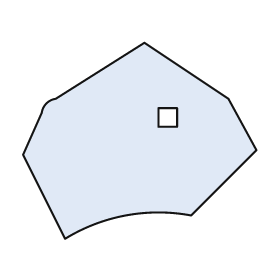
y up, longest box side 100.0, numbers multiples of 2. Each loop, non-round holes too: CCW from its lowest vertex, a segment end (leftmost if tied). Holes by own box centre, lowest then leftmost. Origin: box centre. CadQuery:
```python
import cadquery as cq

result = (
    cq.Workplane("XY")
    .moveTo(-32.0, -42.0)
    .threePointArc((-6.0, -32.0), (22.0, -32.0))
    .lineTo(50.0, -4.0)
    .lineTo(38.0, 18.0)
    .lineTo(2.0, 42.0)
    .lineTo(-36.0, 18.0)
    .threePointArc((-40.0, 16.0), (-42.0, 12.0))
    .lineTo(-50.0, -6.0)
    .close()
    .moveTo(8.0, 6.0)
    .lineTo(16.0, 6.0)
    .lineTo(16.0, 14.0)
    .lineTo(8.0, 14.0)
    .close()
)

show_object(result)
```